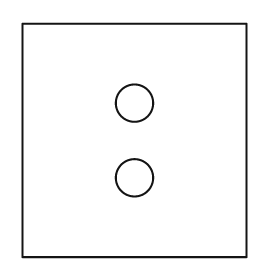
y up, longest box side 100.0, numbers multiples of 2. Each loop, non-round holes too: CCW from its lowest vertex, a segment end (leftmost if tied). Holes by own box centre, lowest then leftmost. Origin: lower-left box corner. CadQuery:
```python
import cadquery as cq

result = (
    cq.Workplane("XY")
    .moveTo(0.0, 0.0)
    .lineTo(96.0, 0.0)
    .lineTo(96.0, 100.0)
    .lineTo(0.0, 100.0)
    .close()
    .moveTo(48.0, 34.0)
    .circle(8.0)
    .moveTo(48.0, 66.0)
    .circle(8.0)
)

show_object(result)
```